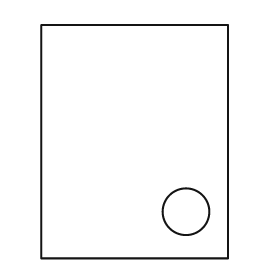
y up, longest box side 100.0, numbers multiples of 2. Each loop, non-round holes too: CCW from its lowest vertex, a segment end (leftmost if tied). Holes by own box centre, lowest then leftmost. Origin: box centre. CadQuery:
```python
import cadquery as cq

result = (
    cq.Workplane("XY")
    .moveTo(-40.0, -50.0)
    .lineTo(40.0, -50.0)
    .lineTo(40.0, 50.0)
    .lineTo(-40.0, 50.0)
    .close()
    .moveTo(22.0, -30.0)
    .circle(10.0)
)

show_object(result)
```